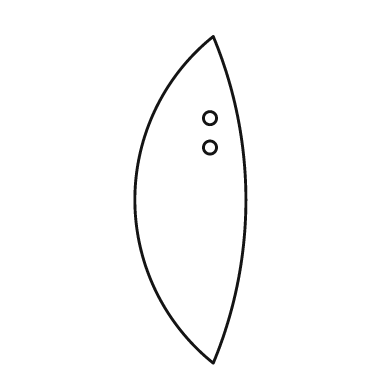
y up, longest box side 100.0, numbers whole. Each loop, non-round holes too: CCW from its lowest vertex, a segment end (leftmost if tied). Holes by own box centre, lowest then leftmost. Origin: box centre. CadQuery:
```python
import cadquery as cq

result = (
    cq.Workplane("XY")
    .moveTo(7.0, -50.0)
    .threePointArc((17.0, 0.0), (7.0, 50.0))
    .threePointArc((-17.0, 0.0), (7.0, -50.0))
    .close()
    .moveTo(6.0, 16.0)
    .circle(2.0)
    .moveTo(6.0, 25.0)
    .circle(2.0)
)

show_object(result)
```